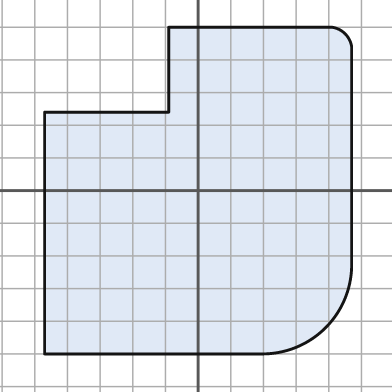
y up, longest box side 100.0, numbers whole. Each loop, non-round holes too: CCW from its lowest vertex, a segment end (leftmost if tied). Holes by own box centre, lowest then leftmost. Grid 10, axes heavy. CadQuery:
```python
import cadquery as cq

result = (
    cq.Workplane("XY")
    .moveTo(-47.0, -50.0)
    .lineTo(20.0, -50.0)
    .threePointArc((39.0, -42.0), (47.0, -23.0))
    .lineTo(47.0, 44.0)
    .threePointArc((45.0, 48.0), (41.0, 50.0))
    .lineTo(-9.0, 50.0)
    .lineTo(-9.0, 24.0)
    .lineTo(-47.0, 24.0)
    .close()
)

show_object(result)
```